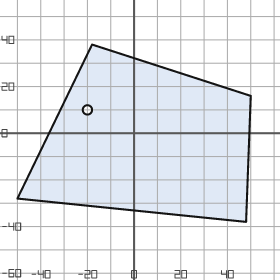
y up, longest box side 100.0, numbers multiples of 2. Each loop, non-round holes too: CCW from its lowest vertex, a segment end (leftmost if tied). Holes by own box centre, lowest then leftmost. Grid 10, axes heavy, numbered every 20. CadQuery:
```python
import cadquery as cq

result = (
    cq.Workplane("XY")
    .moveTo(48.0, -38.0)
    .lineTo(50.0, 16.0)
    .lineTo(-18.0, 38.0)
    .lineTo(-50.0, -28.0)
    .close()
    .moveTo(-20.0, 10.0)
    .circle(2.0)
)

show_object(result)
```